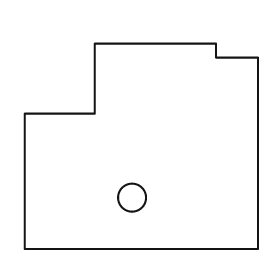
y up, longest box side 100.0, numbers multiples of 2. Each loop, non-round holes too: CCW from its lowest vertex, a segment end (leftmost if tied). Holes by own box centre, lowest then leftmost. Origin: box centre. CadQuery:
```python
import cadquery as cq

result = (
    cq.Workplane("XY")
    .moveTo(-50.0, -44.0)
    .lineTo(50.0, -44.0)
    .lineTo(50.0, 38.0)
    .lineTo(32.0, 38.0)
    .lineTo(32.0, 44.0)
    .lineTo(-20.0, 44.0)
    .lineTo(-20.0, 14.0)
    .lineTo(-50.0, 14.0)
    .close()
    .moveTo(-4.0, -22.0)
    .circle(6.0)
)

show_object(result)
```